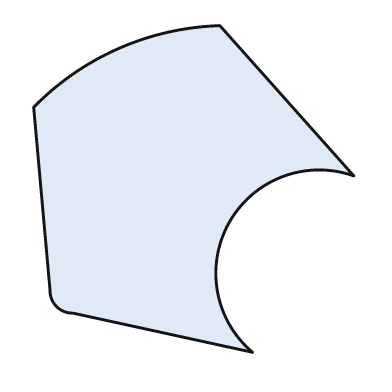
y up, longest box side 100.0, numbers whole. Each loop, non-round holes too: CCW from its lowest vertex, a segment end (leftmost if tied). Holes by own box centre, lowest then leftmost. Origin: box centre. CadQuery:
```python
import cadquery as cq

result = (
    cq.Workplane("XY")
    .moveTo(18.0, -50.0)
    .threePointArc((11.0, -10.0), (49.0, 4.0))
    .lineTo(8.0, 50.0)
    .threePointArc((-23.0, 43.0), (-49.0, 25.0))
    .lineTo(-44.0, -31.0)
    .threePointArc((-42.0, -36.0), (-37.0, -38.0))
    .close()
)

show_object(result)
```